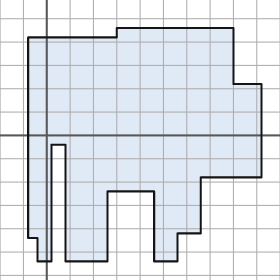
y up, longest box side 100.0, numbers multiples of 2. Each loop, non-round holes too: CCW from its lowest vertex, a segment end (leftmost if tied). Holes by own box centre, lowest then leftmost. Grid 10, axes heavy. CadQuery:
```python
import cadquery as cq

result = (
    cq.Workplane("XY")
    .moveTo(-4.0, -54.0)
    .lineTo(2.0, -54.0)
    .lineTo(2.0, -4.0)
    .lineTo(8.0, -4.0)
    .lineTo(8.0, -54.0)
    .lineTo(26.0, -54.0)
    .lineTo(26.0, -24.0)
    .lineTo(46.0, -24.0)
    .lineTo(46.0, -54.0)
    .lineTo(56.0, -54.0)
    .lineTo(56.0, -42.0)
    .lineTo(66.0, -42.0)
    .lineTo(66.0, -18.0)
    .lineTo(92.0, -18.0)
    .lineTo(92.0, 22.0)
    .lineTo(80.0, 22.0)
    .lineTo(80.0, 46.0)
    .lineTo(30.0, 46.0)
    .lineTo(30.0, 42.0)
    .lineTo(-8.0, 42.0)
    .lineTo(-8.0, -44.0)
    .lineTo(-4.0, -44.0)
    .close()
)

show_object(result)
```